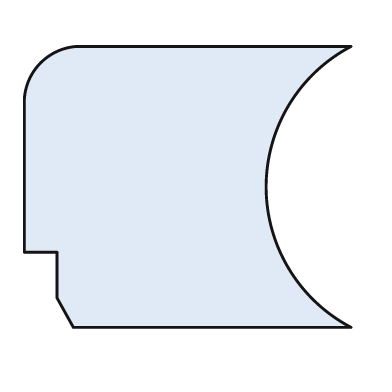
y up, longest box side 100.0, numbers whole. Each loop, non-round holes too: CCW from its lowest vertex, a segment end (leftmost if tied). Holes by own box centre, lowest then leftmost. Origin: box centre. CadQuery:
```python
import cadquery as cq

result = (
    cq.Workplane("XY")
    .moveTo(-35.0, -43.0)
    .lineTo(50.0, -43.0)
    .threePointArc((24.0, 0.0), (50.0, 43.0))
    .lineTo(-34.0, 43.0)
    .threePointArc((-45.0, 38.0), (-50.0, 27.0))
    .lineTo(-50.0, -20.0)
    .lineTo(-40.0, -20.0)
    .lineTo(-40.0, -34.0)
    .close()
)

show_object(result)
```